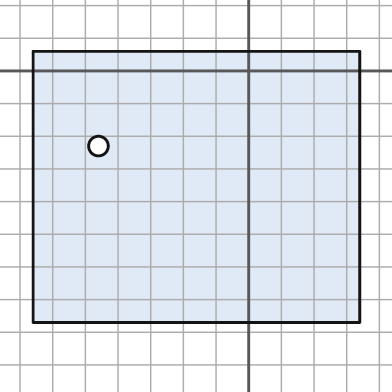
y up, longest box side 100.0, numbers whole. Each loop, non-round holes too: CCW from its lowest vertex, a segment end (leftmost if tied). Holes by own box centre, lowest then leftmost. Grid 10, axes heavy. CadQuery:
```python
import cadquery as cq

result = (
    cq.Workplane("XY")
    .moveTo(-66.0, -77.0)
    .lineTo(34.0, -77.0)
    .lineTo(34.0, 6.0)
    .lineTo(-66.0, 6.0)
    .close()
    .moveTo(-46.0, -23.0)
    .circle(3.0)
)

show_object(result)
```